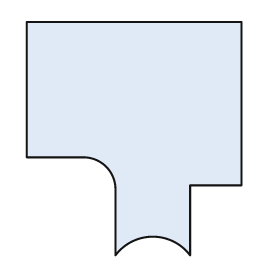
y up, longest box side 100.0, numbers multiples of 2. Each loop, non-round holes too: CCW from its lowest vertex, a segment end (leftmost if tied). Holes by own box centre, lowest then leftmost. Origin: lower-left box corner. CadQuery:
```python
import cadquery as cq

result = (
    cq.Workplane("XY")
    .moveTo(38.0, 0.0)
    .threePointArc((54.0, 8.0), (70.0, 0.0))
    .lineTo(70.0, 30.0)
    .lineTo(92.0, 30.0)
    .lineTo(92.0, 100.0)
    .lineTo(0.0, 100.0)
    .lineTo(0.0, 42.0)
    .lineTo(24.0, 42.0)
    .threePointArc((34.0, 38.0), (38.0, 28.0))
    .close()
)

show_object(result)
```